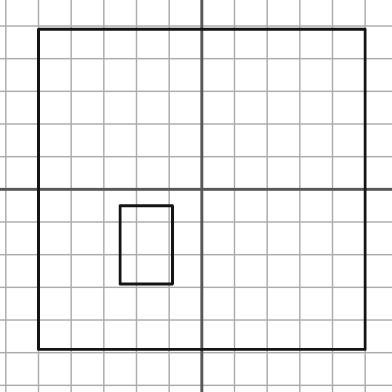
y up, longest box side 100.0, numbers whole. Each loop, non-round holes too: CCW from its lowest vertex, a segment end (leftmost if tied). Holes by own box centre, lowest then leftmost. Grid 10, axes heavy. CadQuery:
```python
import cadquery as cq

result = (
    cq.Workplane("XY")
    .moveTo(-50.0, -49.0)
    .lineTo(50.0, -49.0)
    .lineTo(50.0, 49.0)
    .lineTo(-50.0, 49.0)
    .close()
    .moveTo(-25.0, -29.0)
    .lineTo(-9.0, -29.0)
    .lineTo(-9.0, -5.0)
    .lineTo(-25.0, -5.0)
    .close()
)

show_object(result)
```